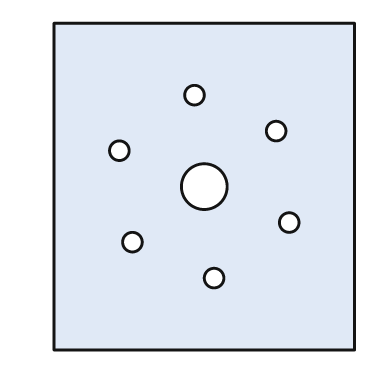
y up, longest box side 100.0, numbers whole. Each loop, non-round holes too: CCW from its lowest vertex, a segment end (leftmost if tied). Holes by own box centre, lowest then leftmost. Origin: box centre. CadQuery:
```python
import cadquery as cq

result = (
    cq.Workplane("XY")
    .moveTo(-46.0, -50.0)
    .lineTo(46.0, -50.0)
    .lineTo(46.0, 50.0)
    .lineTo(-46.0, 50.0)
    .close()
    .moveTo(3.0, -28.0)
    .circle(3.0)
    .moveTo(-22.0, -17.0)
    .circle(3.0)
    .moveTo(26.0, -11.0)
    .circle(3.0)
    .moveTo(0.0, 0.0)
    .circle(7.0)
    .moveTo(-26.0, 11.0)
    .circle(3.0)
    .moveTo(22.0, 17.0)
    .circle(3.0)
    .moveTo(-3.0, 28.0)
    .circle(3.0)
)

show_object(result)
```